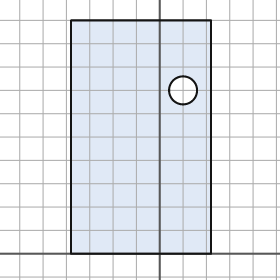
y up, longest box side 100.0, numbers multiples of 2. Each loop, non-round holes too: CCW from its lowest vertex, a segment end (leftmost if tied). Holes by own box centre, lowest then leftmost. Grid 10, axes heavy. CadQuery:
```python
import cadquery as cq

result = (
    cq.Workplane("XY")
    .moveTo(-38.0, 0.0)
    .lineTo(22.0, 0.0)
    .lineTo(22.0, 100.0)
    .lineTo(-38.0, 100.0)
    .close()
    .moveTo(10.0, 70.0)
    .circle(6.0)
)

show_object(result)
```